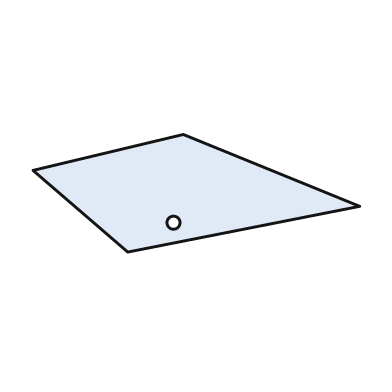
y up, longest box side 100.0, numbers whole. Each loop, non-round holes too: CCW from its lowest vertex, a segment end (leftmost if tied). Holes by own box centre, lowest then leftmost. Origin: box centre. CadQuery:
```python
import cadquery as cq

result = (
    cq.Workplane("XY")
    .moveTo(-21.0, -18.0)
    .lineTo(50.0, -4.0)
    .lineTo(-4.0, 18.0)
    .lineTo(-50.0, 7.0)
    .close()
    .moveTo(-7.0, -9.0)
    .circle(2.0)
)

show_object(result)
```